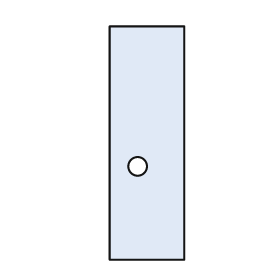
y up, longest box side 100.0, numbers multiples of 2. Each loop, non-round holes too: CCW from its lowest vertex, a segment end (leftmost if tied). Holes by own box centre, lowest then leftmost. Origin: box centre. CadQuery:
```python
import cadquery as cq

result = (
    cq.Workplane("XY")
    .moveTo(-16.0, -50.0)
    .lineTo(16.0, -50.0)
    .lineTo(16.0, 50.0)
    .lineTo(-16.0, 50.0)
    .close()
    .moveTo(-4.0, -10.0)
    .circle(4.0)
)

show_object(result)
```